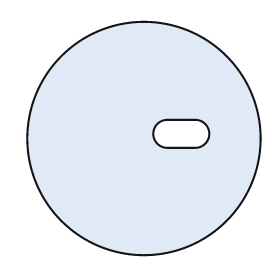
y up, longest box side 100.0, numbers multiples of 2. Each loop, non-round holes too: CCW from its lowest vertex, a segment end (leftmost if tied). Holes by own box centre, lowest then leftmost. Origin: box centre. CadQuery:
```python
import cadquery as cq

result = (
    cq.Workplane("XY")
    .moveTo(0.0, 0.0)
    .circle(50.0)
    .moveTo(10.0, -4.0)
    .lineTo(22.0, -4.0)
    .threePointArc((28.0, 2.0), (22.0, 8.0))
    .lineTo(10.0, 8.0)
    .threePointArc((4.0, 2.0), (10.0, -4.0))
    .close()
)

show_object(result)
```